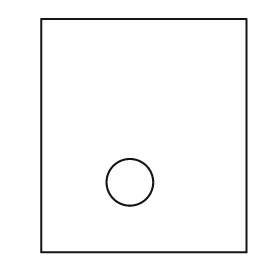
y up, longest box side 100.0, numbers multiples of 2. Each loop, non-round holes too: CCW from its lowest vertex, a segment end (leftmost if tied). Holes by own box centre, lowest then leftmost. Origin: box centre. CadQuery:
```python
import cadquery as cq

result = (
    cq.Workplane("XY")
    .moveTo(-44.0, -50.0)
    .lineTo(44.0, -50.0)
    .lineTo(44.0, 50.0)
    .lineTo(-44.0, 50.0)
    .close()
    .moveTo(-6.0, -20.0)
    .circle(10.0)
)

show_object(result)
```